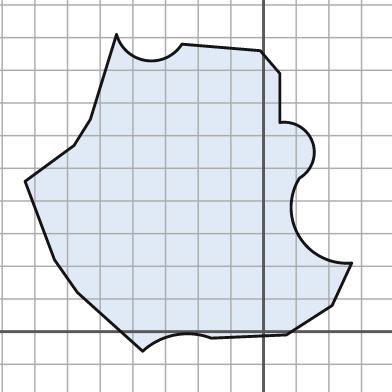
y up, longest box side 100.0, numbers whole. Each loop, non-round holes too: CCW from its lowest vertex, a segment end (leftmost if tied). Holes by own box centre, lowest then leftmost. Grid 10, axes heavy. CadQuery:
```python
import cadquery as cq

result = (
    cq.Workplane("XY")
    .moveTo(-37.0, -6.0)
    .threePointArc((-27.0, -1.0), (-16.0, -2.0))
    .lineTo(7.0, -1.0)
    .lineTo(21.0, 8.0)
    .lineTo(27.0, 21.0)
    .threePointArc((11.0, 29.0), (11.0, 47.0))
    .threePointArc((15.0, 58.0), (5.0, 64.0))
    .lineTo(5.0, 79.0)
    .lineTo(-1.0, 86.0)
    .lineTo(-25.0, 88.0)
    .threePointArc((-36.0, 83.0), (-45.0, 91.0))
    .lineTo(-53.0, 65.0)
    .lineTo(-58.0, 57.0)
    .lineTo(-73.0, 46.0)
    .lineTo(-64.0, 22.0)
    .lineTo(-57.0, 12.0)
    .close()
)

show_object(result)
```